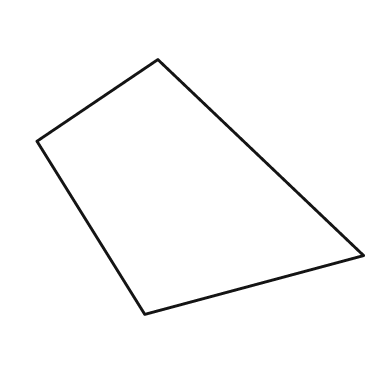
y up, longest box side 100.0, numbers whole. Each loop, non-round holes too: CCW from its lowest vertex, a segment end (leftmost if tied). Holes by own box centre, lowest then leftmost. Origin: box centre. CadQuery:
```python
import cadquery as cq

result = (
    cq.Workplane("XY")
    .moveTo(-17.0, -39.0)
    .lineTo(50.0, -21.0)
    .lineTo(-13.0, 39.0)
    .lineTo(-50.0, 14.0)
    .close()
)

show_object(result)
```